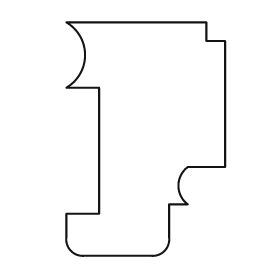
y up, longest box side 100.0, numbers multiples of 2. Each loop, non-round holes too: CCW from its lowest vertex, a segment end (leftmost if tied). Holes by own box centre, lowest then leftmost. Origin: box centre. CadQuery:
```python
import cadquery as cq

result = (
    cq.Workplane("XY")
    .moveTo(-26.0, -50.0)
    .lineTo(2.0, -50.0)
    .threePointArc((8.0, -48.0), (10.0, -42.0))
    .lineTo(10.0, -28.0)
    .lineTo(18.0, -28.0)
    .threePointArc((14.0, -20.0), (18.0, -12.0))
    .lineTo(34.0, -12.0)
    .lineTo(34.0, 42.0)
    .lineTo(26.0, 42.0)
    .lineTo(26.0, 50.0)
    .lineTo(-34.0, 50.0)
    .threePointArc((-26.0, 36.0), (-34.0, 22.0))
    .lineTo(-20.0, 22.0)
    .lineTo(-20.0, -32.0)
    .lineTo(-34.0, -32.0)
    .lineTo(-34.0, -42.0)
    .threePointArc((-32.0, -48.0), (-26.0, -50.0))
    .close()
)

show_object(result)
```